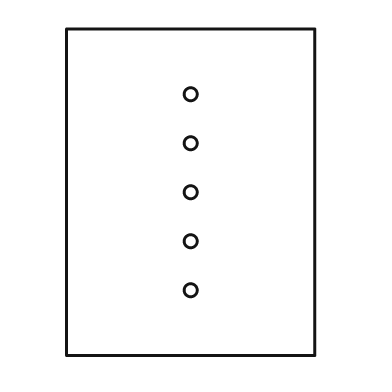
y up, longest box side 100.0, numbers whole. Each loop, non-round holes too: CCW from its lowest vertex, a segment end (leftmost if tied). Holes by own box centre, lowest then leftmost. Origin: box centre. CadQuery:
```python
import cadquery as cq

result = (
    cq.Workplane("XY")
    .moveTo(-38.0, -50.0)
    .lineTo(38.0, -50.0)
    .lineTo(38.0, 50.0)
    .lineTo(-38.0, 50.0)
    .close()
    .moveTo(0.0, -30.0)
    .circle(2.0)
    .moveTo(0.0, -15.0)
    .circle(2.0)
    .moveTo(0.0, 0.0)
    .circle(2.0)
    .moveTo(0.0, 15.0)
    .circle(2.0)
    .moveTo(0.0, 30.0)
    .circle(2.0)
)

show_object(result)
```